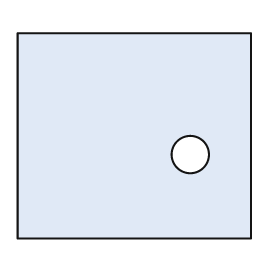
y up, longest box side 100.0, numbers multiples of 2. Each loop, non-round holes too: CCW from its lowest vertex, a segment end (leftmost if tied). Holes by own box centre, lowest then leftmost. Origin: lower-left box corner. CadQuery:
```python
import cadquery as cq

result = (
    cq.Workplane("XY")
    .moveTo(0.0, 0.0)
    .lineTo(100.0, 0.0)
    .lineTo(100.0, 88.0)
    .lineTo(0.0, 88.0)
    .close()
    .moveTo(74.0, 36.0)
    .circle(8.0)
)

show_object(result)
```